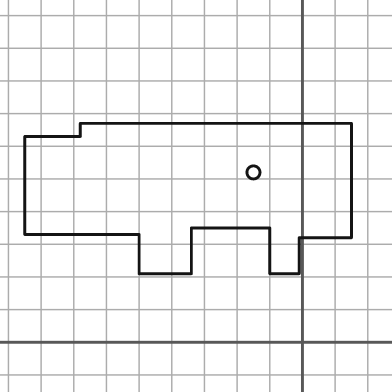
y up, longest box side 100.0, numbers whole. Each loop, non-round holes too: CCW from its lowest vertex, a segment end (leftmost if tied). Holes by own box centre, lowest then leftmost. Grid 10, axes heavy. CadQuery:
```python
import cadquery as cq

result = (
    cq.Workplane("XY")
    .moveTo(-50.0, 21.0)
    .lineTo(-34.0, 21.0)
    .lineTo(-34.0, 35.0)
    .lineTo(-10.0, 35.0)
    .lineTo(-10.0, 21.0)
    .lineTo(-1.0, 21.0)
    .lineTo(-1.0, 32.0)
    .lineTo(15.0, 32.0)
    .lineTo(15.0, 67.0)
    .lineTo(-68.0, 67.0)
    .lineTo(-68.0, 63.0)
    .lineTo(-85.0, 63.0)
    .lineTo(-85.0, 33.0)
    .lineTo(-50.0, 33.0)
    .close()
    .moveTo(-15.0, 52.0)
    .circle(2.0)
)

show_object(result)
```